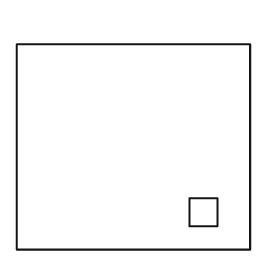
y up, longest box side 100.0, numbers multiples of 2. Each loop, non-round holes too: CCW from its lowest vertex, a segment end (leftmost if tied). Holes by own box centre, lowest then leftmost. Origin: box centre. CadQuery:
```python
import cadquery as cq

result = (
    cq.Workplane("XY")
    .moveTo(-50.0, -44.0)
    .lineTo(50.0, -44.0)
    .lineTo(50.0, 44.0)
    .lineTo(-50.0, 44.0)
    .close()
    .moveTo(24.0, -34.0)
    .lineTo(36.0, -34.0)
    .lineTo(36.0, -22.0)
    .lineTo(24.0, -22.0)
    .close()
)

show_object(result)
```